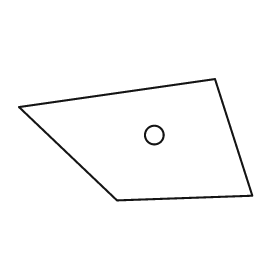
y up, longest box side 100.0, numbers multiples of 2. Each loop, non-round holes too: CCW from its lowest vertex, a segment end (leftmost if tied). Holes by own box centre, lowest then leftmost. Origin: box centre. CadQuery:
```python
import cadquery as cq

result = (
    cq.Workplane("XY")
    .moveTo(-8.0, -26.0)
    .lineTo(50.0, -24.0)
    .lineTo(34.0, 26.0)
    .lineTo(-50.0, 14.0)
    .close()
    .moveTo(8.0, 2.0)
    .circle(4.0)
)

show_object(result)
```